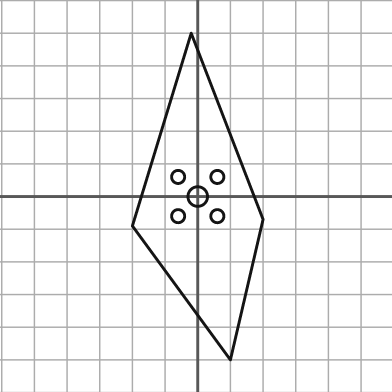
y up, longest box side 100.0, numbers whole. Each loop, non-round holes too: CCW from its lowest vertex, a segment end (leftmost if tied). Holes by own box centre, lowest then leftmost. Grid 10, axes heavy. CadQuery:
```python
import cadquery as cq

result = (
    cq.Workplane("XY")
    .moveTo(10.0, -50.0)
    .lineTo(20.0, -7.0)
    .lineTo(-2.0, 50.0)
    .lineTo(-20.0, -9.0)
    .close()
    .moveTo(-6.0, -6.0)
    .circle(2.0)
    .moveTo(6.0, -6.0)
    .circle(2.0)
    .moveTo(0.0, 0.0)
    .circle(3.0)
    .moveTo(-6.0, 6.0)
    .circle(2.0)
    .moveTo(6.0, 6.0)
    .circle(2.0)
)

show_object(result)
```